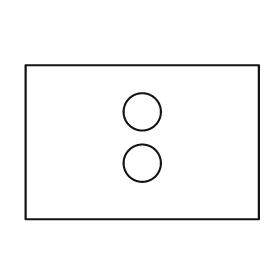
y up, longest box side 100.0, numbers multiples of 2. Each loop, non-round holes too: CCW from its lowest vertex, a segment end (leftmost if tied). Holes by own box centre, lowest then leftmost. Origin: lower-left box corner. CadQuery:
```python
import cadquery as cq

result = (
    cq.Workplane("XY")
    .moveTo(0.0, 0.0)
    .lineTo(100.0, 0.0)
    .lineTo(100.0, 66.0)
    .lineTo(0.0, 66.0)
    .close()
    .moveTo(50.0, 24.0)
    .circle(8.0)
    .moveTo(50.0, 46.0)
    .circle(8.0)
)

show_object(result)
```